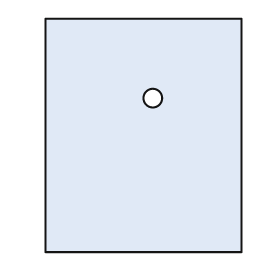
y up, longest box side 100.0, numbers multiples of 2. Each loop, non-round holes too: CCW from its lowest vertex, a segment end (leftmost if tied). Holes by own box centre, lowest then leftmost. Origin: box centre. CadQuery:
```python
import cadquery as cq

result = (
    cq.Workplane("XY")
    .moveTo(-42.0, -50.0)
    .lineTo(42.0, -50.0)
    .lineTo(42.0, 50.0)
    .lineTo(-42.0, 50.0)
    .close()
    .moveTo(4.0, 16.0)
    .circle(4.0)
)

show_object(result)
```